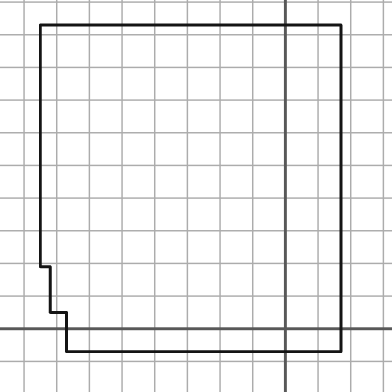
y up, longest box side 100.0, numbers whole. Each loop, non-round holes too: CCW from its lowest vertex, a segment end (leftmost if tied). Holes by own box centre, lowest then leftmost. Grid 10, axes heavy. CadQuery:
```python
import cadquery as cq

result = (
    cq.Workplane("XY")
    .moveTo(-67.0, -7.0)
    .lineTo(17.0, -7.0)
    .lineTo(17.0, 93.0)
    .lineTo(-75.0, 93.0)
    .lineTo(-75.0, 19.0)
    .lineTo(-72.0, 19.0)
    .lineTo(-72.0, 5.0)
    .lineTo(-67.0, 5.0)
    .close()
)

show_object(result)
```